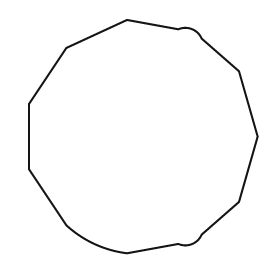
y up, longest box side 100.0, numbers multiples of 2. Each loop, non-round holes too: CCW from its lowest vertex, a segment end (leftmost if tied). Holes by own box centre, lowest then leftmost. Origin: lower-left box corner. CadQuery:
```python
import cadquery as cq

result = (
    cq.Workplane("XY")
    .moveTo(42.0, 0.0)
    .lineTo(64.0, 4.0)
    .threePointArc((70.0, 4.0), (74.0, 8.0))
    .lineTo(90.0, 22.0)
    .lineTo(98.0, 50.0)
    .lineTo(90.0, 78.0)
    .lineTo(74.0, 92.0)
    .threePointArc((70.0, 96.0), (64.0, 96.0))
    .lineTo(42.0, 100.0)
    .lineTo(16.0, 88.0)
    .lineTo(0.0, 64.0)
    .lineTo(0.0, 36.0)
    .lineTo(16.0, 12.0)
    .threePointArc((28.0, 4.0), (42.0, 0.0))
    .close()
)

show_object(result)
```